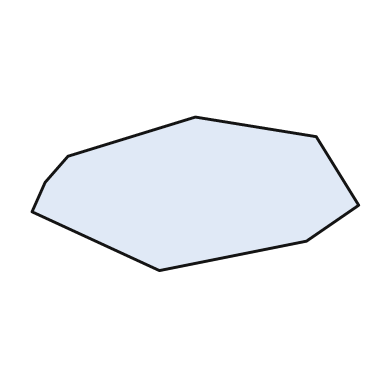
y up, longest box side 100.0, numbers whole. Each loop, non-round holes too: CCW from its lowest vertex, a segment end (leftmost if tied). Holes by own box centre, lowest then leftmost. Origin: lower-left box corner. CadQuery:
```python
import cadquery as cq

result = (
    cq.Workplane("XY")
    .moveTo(39.0, 0.0)
    .lineTo(84.0, 9.0)
    .lineTo(100.0, 20.0)
    .lineTo(87.0, 41.0)
    .lineTo(50.0, 47.0)
    .lineTo(11.0, 35.0)
    .lineTo(4.0, 27.0)
    .lineTo(0.0, 18.0)
    .close()
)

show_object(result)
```